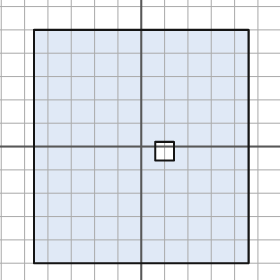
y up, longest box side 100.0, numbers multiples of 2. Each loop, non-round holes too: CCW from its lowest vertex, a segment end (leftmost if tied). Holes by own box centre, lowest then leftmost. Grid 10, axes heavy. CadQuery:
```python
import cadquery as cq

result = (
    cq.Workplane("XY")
    .moveTo(-46.0, -50.0)
    .lineTo(46.0, -50.0)
    .lineTo(46.0, 50.0)
    .lineTo(-46.0, 50.0)
    .close()
    .moveTo(6.0, -6.0)
    .lineTo(14.0, -6.0)
    .lineTo(14.0, 2.0)
    .lineTo(6.0, 2.0)
    .close()
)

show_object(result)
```